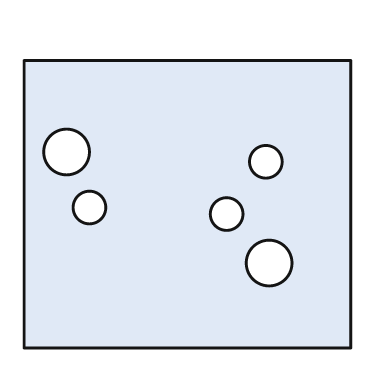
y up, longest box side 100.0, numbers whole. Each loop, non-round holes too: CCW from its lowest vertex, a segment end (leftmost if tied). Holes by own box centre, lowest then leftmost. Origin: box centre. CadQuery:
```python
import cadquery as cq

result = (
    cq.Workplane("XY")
    .moveTo(-50.0, -44.0)
    .lineTo(50.0, -44.0)
    .lineTo(50.0, 44.0)
    .lineTo(-50.0, 44.0)
    .close()
    .moveTo(25.0, -18.0)
    .circle(7.0)
    .moveTo(12.0, -3.0)
    .circle(5.0)
    .moveTo(-30.0, -1.0)
    .circle(5.0)
    .moveTo(24.0, 13.0)
    .circle(5.0)
    .moveTo(-37.0, 16.0)
    .circle(7.0)
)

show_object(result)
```